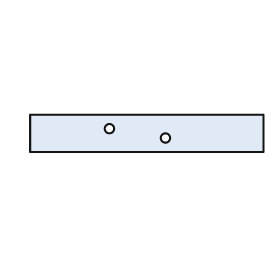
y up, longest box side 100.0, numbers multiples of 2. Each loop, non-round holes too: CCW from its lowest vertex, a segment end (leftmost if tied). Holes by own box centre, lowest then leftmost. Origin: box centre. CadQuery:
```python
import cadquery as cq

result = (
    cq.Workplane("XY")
    .moveTo(-50.0, -8.0)
    .lineTo(50.0, -8.0)
    .lineTo(50.0, 8.0)
    .lineTo(-50.0, 8.0)
    .close()
    .moveTo(8.0, -2.0)
    .circle(2.0)
    .moveTo(-16.0, 2.0)
    .circle(2.0)
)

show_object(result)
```